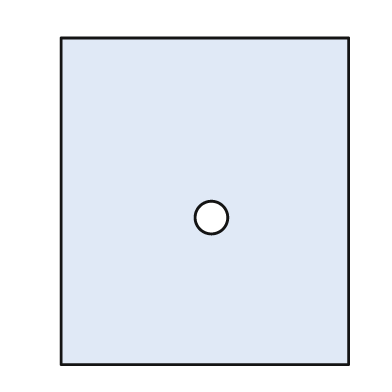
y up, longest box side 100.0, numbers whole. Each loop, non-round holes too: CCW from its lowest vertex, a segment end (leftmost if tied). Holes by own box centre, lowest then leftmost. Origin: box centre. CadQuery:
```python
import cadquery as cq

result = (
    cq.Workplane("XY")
    .moveTo(-44.0, -50.0)
    .lineTo(44.0, -50.0)
    .lineTo(44.0, 50.0)
    .lineTo(-44.0, 50.0)
    .close()
    .moveTo(2.0, -5.0)
    .circle(5.0)
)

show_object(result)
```